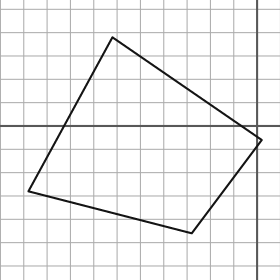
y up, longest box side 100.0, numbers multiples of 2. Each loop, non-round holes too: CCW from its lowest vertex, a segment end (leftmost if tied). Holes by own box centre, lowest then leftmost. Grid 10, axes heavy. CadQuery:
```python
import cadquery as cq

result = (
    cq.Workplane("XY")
    .moveTo(-28.0, -46.0)
    .lineTo(2.0, -6.0)
    .lineTo(-62.0, 38.0)
    .lineTo(-98.0, -28.0)
    .close()
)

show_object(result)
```